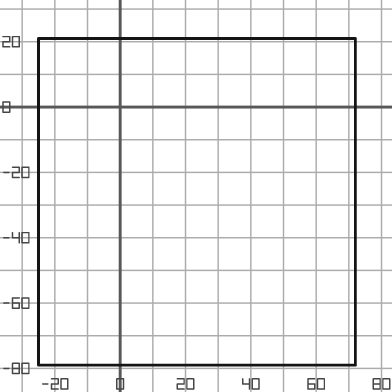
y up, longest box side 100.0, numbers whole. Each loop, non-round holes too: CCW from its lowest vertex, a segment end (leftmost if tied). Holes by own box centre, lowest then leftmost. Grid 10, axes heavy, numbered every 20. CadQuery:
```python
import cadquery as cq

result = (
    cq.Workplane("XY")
    .moveTo(-25.0, -79.0)
    .lineTo(72.0, -79.0)
    .lineTo(72.0, 21.0)
    .lineTo(-25.0, 21.0)
    .close()
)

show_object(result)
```